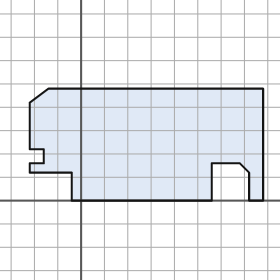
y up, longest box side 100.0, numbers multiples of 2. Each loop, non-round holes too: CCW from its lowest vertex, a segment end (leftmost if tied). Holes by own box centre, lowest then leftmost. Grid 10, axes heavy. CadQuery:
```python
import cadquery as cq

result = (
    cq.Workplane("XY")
    .moveTo(-4.0, 0.0)
    .lineTo(56.0, 0.0)
    .lineTo(56.0, 16.0)
    .lineTo(68.0, 16.0)
    .lineTo(72.0, 12.0)
    .lineTo(72.0, 0.0)
    .lineTo(78.0, 0.0)
    .lineTo(78.0, 48.0)
    .lineTo(-14.0, 48.0)
    .lineTo(-22.0, 42.0)
    .lineTo(-22.0, 22.0)
    .lineTo(-16.0, 22.0)
    .lineTo(-16.0, 16.0)
    .lineTo(-22.0, 16.0)
    .lineTo(-22.0, 12.0)
    .lineTo(-4.0, 12.0)
    .close()
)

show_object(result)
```